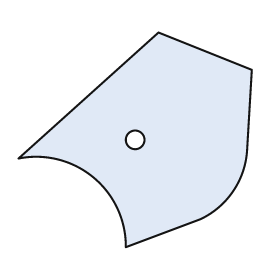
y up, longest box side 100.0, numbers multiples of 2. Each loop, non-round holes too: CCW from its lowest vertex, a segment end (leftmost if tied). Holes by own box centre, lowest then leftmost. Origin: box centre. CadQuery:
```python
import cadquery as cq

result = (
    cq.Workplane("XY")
    .moveTo(-4.0, -46.0)
    .lineTo(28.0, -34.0)
    .threePointArc((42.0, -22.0), (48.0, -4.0))
    .lineTo(50.0, 30.0)
    .lineTo(10.0, 46.0)
    .lineTo(-50.0, -8.0)
    .threePointArc((-18.0, -16.0), (-4.0, -46.0))
    .close()
    .moveTo(0.0, 0.0)
    .circle(4.0)
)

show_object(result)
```